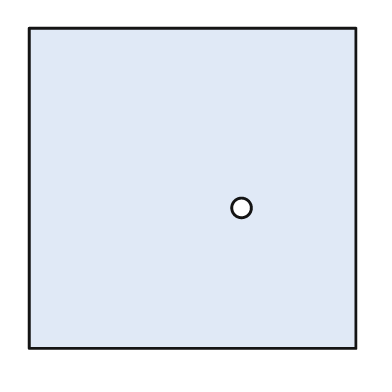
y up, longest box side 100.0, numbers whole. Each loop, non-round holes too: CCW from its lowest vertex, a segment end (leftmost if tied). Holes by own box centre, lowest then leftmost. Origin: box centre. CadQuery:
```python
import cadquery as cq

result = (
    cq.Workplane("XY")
    .moveTo(-50.0, -49.0)
    .lineTo(50.0, -49.0)
    .lineTo(50.0, 49.0)
    .lineTo(-50.0, 49.0)
    .close()
    .moveTo(15.0, -6.0)
    .circle(3.0)
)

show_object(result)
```